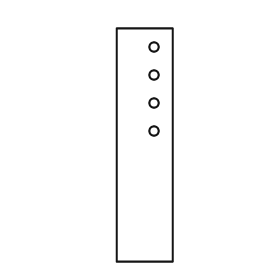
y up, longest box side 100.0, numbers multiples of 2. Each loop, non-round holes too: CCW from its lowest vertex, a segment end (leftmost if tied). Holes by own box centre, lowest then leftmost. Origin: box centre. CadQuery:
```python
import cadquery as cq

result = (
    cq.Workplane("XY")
    .moveTo(-12.0, -50.0)
    .lineTo(12.0, -50.0)
    .lineTo(12.0, 50.0)
    .lineTo(-12.0, 50.0)
    .close()
    .moveTo(4.0, 6.0)
    .circle(2.0)
    .moveTo(4.0, 18.0)
    .circle(2.0)
    .moveTo(4.0, 30.0)
    .circle(2.0)
    .moveTo(4.0, 42.0)
    .circle(2.0)
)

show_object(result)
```